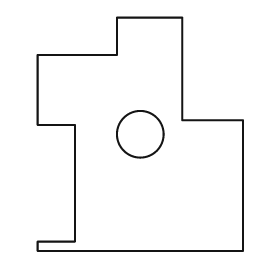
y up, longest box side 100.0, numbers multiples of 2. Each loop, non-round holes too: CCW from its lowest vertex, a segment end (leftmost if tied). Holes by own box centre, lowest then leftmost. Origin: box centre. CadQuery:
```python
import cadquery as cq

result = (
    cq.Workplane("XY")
    .moveTo(-44.0, -50.0)
    .lineTo(44.0, -50.0)
    .lineTo(44.0, 6.0)
    .lineTo(18.0, 6.0)
    .lineTo(18.0, 50.0)
    .lineTo(-10.0, 50.0)
    .lineTo(-10.0, 34.0)
    .lineTo(-44.0, 34.0)
    .lineTo(-44.0, 4.0)
    .lineTo(-28.0, 4.0)
    .lineTo(-28.0, -46.0)
    .lineTo(-44.0, -46.0)
    .close()
    .moveTo(0.0, 0.0)
    .circle(10.0)
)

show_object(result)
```